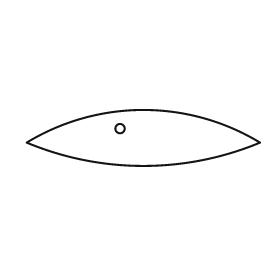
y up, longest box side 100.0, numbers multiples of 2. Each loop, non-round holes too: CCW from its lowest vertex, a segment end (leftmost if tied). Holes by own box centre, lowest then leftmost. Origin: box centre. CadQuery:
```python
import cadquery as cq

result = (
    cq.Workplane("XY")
    .moveTo(-50.0, -2.0)
    .threePointArc((0.0, -12.0), (50.0, -2.0))
    .threePointArc((0.0, 12.0), (-50.0, -2.0))
    .close()
    .moveTo(-10.0, 4.0)
    .circle(2.0)
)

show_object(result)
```